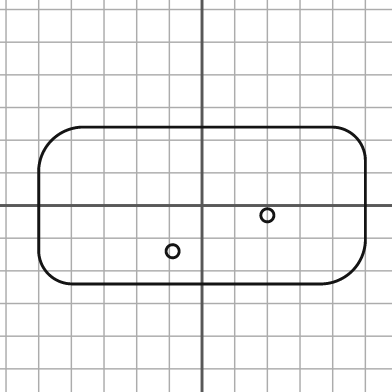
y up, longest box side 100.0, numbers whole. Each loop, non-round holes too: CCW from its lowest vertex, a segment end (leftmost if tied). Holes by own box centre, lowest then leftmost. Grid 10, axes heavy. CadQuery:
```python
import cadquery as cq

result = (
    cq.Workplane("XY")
    .moveTo(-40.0, -24.0)
    .lineTo(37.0, -24.0)
    .threePointArc((46.0, -20.0), (50.0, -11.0))
    .lineTo(50.0, 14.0)
    .threePointArc((47.0, 21.0), (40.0, 24.0))
    .lineTo(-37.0, 24.0)
    .threePointArc((-46.0, 20.0), (-50.0, 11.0))
    .lineTo(-50.0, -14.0)
    .threePointArc((-47.0, -21.0), (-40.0, -24.0))
    .close()
    .moveTo(-9.0, -14.0)
    .circle(2.0)
    .moveTo(20.0, -3.0)
    .circle(2.0)
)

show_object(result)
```